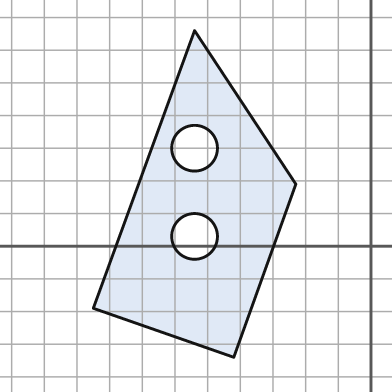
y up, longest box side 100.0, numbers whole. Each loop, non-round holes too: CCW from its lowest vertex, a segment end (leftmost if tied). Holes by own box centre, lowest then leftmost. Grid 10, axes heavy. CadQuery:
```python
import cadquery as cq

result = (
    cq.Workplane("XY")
    .moveTo(-42.0, -34.0)
    .lineTo(-23.0, 19.0)
    .lineTo(-54.0, 66.0)
    .lineTo(-85.0, -19.0)
    .close()
    .moveTo(-54.0, 3.0)
    .circle(7.0)
    .moveTo(-54.0, 30.0)
    .circle(7.0)
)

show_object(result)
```